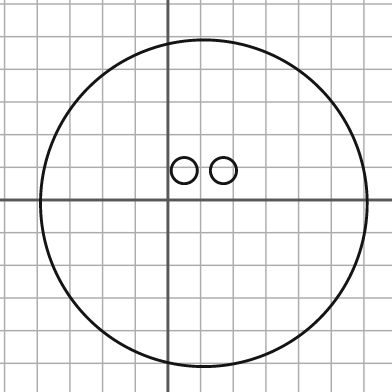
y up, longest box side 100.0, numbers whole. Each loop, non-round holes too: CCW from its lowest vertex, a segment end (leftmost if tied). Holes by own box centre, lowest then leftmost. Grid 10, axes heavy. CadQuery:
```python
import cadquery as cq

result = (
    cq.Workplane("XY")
    .moveTo(11.0, -1.0)
    .circle(50.0)
    .moveTo(5.0, 9.0)
    .circle(4.0)
    .moveTo(17.0, 9.0)
    .circle(4.0)
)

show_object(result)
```